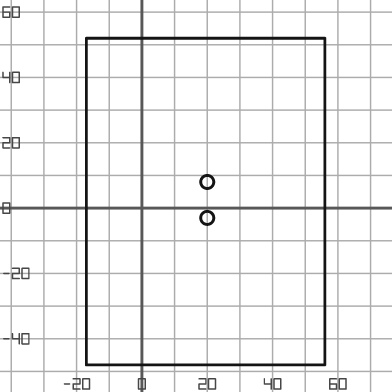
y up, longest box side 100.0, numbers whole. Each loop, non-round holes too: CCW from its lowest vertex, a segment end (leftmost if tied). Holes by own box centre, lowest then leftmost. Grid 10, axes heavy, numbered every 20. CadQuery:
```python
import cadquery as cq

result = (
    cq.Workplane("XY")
    .moveTo(-17.0, -48.0)
    .lineTo(56.0, -48.0)
    .lineTo(56.0, 52.0)
    .lineTo(-17.0, 52.0)
    .close()
    .moveTo(20.0, -3.0)
    .circle(2.0)
    .moveTo(20.0, 8.0)
    .circle(2.0)
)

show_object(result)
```